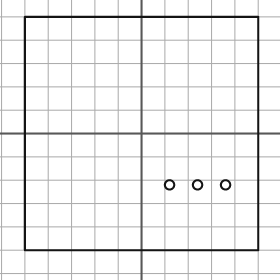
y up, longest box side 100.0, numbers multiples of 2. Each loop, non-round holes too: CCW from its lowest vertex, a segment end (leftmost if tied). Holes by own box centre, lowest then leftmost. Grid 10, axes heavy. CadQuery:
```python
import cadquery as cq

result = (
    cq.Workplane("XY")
    .moveTo(-50.0, -50.0)
    .lineTo(50.0, -50.0)
    .lineTo(50.0, 50.0)
    .lineTo(-50.0, 50.0)
    .close()
    .moveTo(12.0, -22.0)
    .circle(2.0)
    .moveTo(24.0, -22.0)
    .circle(2.0)
    .moveTo(36.0, -22.0)
    .circle(2.0)
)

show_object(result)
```